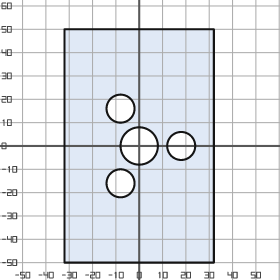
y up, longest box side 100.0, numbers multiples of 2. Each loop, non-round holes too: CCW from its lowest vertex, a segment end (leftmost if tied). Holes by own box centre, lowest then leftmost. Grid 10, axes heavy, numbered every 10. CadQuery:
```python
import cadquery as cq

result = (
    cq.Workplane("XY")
    .moveTo(-32.0, -50.0)
    .lineTo(32.0, -50.0)
    .lineTo(32.0, 50.0)
    .lineTo(-32.0, 50.0)
    .close()
    .moveTo(-8.0, -16.0)
    .circle(6.0)
    .moveTo(0.0, 0.0)
    .circle(8.0)
    .moveTo(18.0, 0.0)
    .circle(6.0)
    .moveTo(-8.0, 16.0)
    .circle(6.0)
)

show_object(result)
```